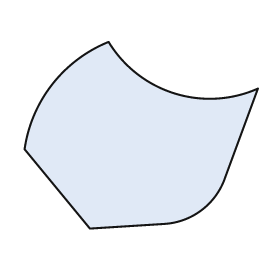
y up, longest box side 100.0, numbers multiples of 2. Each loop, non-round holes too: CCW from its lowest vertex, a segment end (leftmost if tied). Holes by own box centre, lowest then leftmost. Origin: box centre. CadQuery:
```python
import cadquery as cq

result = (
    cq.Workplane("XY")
    .moveTo(-22.0, -40.0)
    .lineTo(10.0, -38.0)
    .threePointArc((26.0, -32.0), (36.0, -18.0))
    .lineTo(50.0, 20.0)
    .threePointArc((14.0, 18.0), (-14.0, 40.0))
    .threePointArc((-38.0, 22.0), (-50.0, -6.0))
    .close()
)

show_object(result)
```